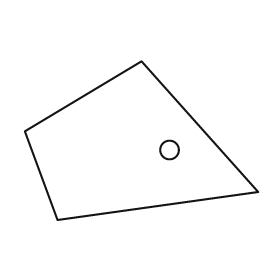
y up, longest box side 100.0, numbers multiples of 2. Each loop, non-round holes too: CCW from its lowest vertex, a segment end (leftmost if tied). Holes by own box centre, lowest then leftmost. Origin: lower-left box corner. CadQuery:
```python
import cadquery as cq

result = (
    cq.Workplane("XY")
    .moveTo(14.0, 0.0)
    .lineTo(100.0, 12.0)
    .lineTo(50.0, 68.0)
    .lineTo(0.0, 38.0)
    .close()
    .moveTo(62.0, 30.0)
    .circle(4.0)
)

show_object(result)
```